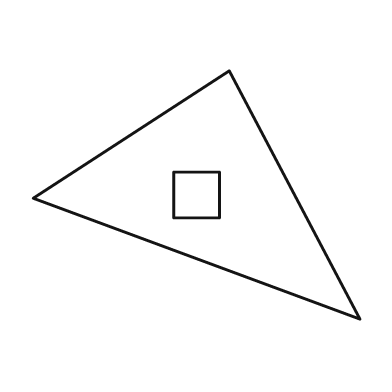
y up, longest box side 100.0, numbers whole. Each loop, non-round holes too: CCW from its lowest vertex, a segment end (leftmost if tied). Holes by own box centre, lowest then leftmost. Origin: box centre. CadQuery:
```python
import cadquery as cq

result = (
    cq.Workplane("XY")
    .moveTo(50.0, -38.0)
    .lineTo(10.0, 38.0)
    .lineTo(-50.0, -1.0)
    .close()
    .moveTo(-7.0, -7.0)
    .lineTo(7.0, -7.0)
    .lineTo(7.0, 7.0)
    .lineTo(-7.0, 7.0)
    .close()
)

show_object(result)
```